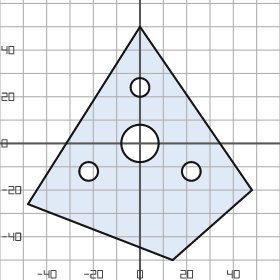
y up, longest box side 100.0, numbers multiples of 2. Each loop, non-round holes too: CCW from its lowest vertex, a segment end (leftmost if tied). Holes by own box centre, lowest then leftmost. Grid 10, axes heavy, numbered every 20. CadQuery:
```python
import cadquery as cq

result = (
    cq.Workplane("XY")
    .moveTo(14.0, -50.0)
    .lineTo(48.0, -20.0)
    .lineTo(0.0, 50.0)
    .lineTo(-48.0, -26.0)
    .close()
    .moveTo(-22.0, -12.0)
    .circle(4.0)
    .moveTo(22.0, -12.0)
    .circle(4.0)
    .moveTo(0.0, 0.0)
    .circle(8.0)
    .moveTo(0.0, 24.0)
    .circle(4.0)
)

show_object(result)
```